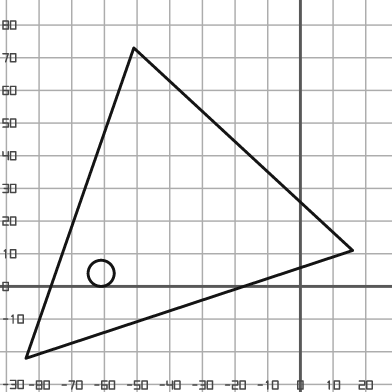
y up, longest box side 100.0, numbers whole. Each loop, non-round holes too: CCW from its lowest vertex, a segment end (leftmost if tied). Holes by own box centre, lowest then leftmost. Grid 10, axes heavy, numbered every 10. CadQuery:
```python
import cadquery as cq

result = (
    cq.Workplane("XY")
    .moveTo(-84.0, -22.0)
    .lineTo(16.0, 11.0)
    .lineTo(-51.0, 73.0)
    .close()
    .moveTo(-61.0, 4.0)
    .circle(4.0)
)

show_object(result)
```